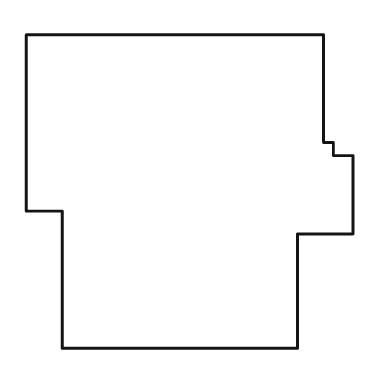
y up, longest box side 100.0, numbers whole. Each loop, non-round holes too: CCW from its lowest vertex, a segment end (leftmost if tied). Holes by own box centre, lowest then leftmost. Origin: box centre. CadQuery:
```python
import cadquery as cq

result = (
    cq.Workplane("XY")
    .moveTo(-39.0, -48.0)
    .lineTo(33.0, -48.0)
    .lineTo(33.0, -13.0)
    .lineTo(50.0, -13.0)
    .lineTo(50.0, 11.0)
    .lineTo(44.0, 11.0)
    .lineTo(44.0, 15.0)
    .lineTo(41.0, 15.0)
    .lineTo(41.0, 48.0)
    .lineTo(-50.0, 48.0)
    .lineTo(-50.0, -6.0)
    .lineTo(-39.0, -6.0)
    .close()
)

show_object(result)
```